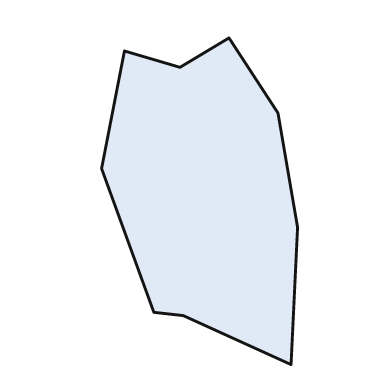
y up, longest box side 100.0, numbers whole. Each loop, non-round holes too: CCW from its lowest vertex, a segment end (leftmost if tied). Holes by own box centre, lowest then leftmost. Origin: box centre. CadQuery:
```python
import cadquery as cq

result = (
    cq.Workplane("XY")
    .moveTo(28.0, -50.0)
    .lineTo(30.0, -8.0)
    .lineTo(24.0, 27.0)
    .lineTo(9.0, 50.0)
    .lineTo(-6.0, 41.0)
    .lineTo(-23.0, 46.0)
    .lineTo(-30.0, 10.0)
    .lineTo(-14.0, -34.0)
    .lineTo(-5.0, -35.0)
    .close()
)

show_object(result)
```